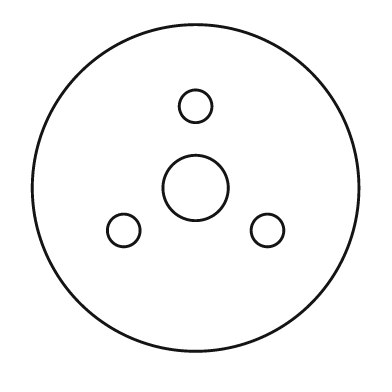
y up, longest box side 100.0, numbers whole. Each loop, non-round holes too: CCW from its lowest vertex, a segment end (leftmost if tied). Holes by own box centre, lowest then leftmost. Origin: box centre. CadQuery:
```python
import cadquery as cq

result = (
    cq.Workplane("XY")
    .moveTo(0.0, 0.0)
    .circle(50.0)
    .moveTo(-22.0, -13.0)
    .circle(5.0)
    .moveTo(22.0, -13.0)
    .circle(5.0)
    .moveTo(0.0, 0.0)
    .circle(10.0)
    .moveTo(0.0, 25.0)
    .circle(5.0)
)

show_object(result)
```